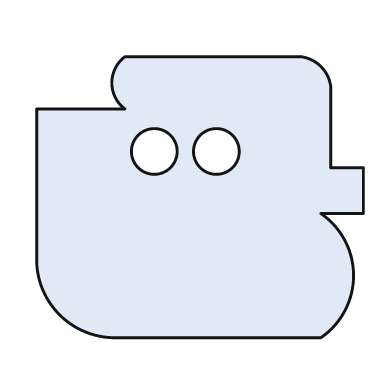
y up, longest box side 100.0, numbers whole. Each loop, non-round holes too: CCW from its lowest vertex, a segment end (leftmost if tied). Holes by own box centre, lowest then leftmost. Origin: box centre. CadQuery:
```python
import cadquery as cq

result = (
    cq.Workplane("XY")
    .moveTo(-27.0, -43.0)
    .lineTo(37.0, -43.0)
    .threePointArc((47.0, -24.0), (37.0, -5.0))
    .lineTo(50.0, -5.0)
    .lineTo(50.0, 9.0)
    .lineTo(40.0, 9.0)
    .lineTo(40.0, 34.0)
    .threePointArc((37.0, 40.0), (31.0, 43.0))
    .lineTo(-23.0, 43.0)
    .threePointArc((-27.0, 35.0), (-23.0, 27.0))
    .lineTo(-50.0, 27.0)
    .lineTo(-50.0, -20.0)
    .threePointArc((-43.0, -36.0), (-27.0, -43.0))
    .close()
    .moveTo(-14.0, 14.0)
    .circle(7.0)
    .moveTo(5.0, 14.0)
    .circle(7.0)
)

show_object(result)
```